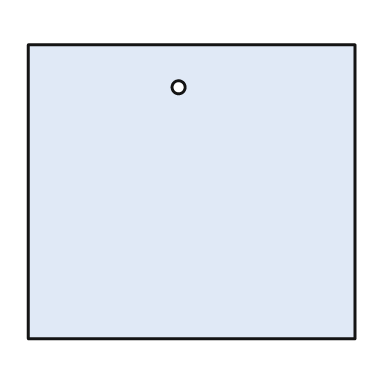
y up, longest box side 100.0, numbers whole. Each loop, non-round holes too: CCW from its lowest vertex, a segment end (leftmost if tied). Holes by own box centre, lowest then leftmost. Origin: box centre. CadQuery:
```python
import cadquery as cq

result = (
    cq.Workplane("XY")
    .moveTo(-50.0, -45.0)
    .lineTo(50.0, -45.0)
    .lineTo(50.0, 45.0)
    .lineTo(-50.0, 45.0)
    .close()
    .moveTo(-4.0, 32.0)
    .circle(2.0)
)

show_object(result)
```